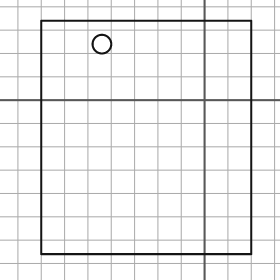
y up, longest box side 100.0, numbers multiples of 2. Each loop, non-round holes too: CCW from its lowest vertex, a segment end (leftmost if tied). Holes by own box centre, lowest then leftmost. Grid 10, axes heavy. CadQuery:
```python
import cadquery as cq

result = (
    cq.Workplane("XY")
    .moveTo(-70.0, -66.0)
    .lineTo(20.0, -66.0)
    .lineTo(20.0, 34.0)
    .lineTo(-70.0, 34.0)
    .close()
    .moveTo(-44.0, 24.0)
    .circle(4.0)
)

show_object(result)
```